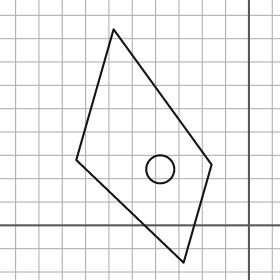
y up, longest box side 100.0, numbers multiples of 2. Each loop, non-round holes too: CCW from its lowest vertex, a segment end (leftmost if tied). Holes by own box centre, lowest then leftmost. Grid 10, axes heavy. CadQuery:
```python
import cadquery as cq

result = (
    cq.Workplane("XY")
    .moveTo(-28.0, -16.0)
    .lineTo(-16.0, 26.0)
    .lineTo(-58.0, 84.0)
    .lineTo(-74.0, 28.0)
    .close()
    .moveTo(-38.0, 24.0)
    .circle(6.0)
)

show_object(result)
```